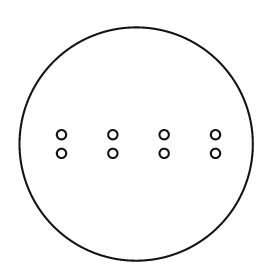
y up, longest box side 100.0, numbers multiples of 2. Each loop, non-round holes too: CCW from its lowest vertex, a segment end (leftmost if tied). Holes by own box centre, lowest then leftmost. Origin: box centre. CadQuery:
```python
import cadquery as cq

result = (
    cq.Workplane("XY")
    .moveTo(0.0, 0.0)
    .circle(50.0)
    .moveTo(-32.0, -4.0)
    .circle(2.0)
    .moveTo(-10.0, -4.0)
    .circle(2.0)
    .moveTo(12.0, -4.0)
    .circle(2.0)
    .moveTo(34.0, -4.0)
    .circle(2.0)
    .moveTo(-32.0, 4.0)
    .circle(2.0)
    .moveTo(-10.0, 4.0)
    .circle(2.0)
    .moveTo(12.0, 4.0)
    .circle(2.0)
    .moveTo(34.0, 4.0)
    .circle(2.0)
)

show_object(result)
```